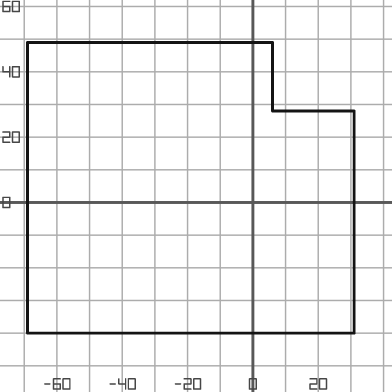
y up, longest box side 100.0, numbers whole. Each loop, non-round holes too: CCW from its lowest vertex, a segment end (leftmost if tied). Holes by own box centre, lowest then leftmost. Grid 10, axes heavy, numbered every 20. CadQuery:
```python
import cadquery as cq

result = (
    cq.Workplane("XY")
    .moveTo(-69.0, -40.0)
    .lineTo(31.0, -40.0)
    .lineTo(31.0, 28.0)
    .lineTo(6.0, 28.0)
    .lineTo(6.0, 49.0)
    .lineTo(-69.0, 49.0)
    .close()
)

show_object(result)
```